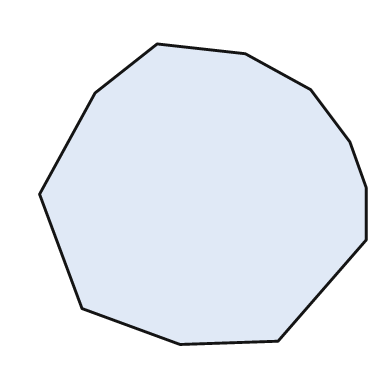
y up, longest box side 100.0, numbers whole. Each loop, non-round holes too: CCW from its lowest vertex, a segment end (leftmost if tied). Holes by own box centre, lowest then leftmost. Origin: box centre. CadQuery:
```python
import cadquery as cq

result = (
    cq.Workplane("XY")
    .moveTo(-7.0, -46.0)
    .lineTo(23.0, -45.0)
    .lineTo(50.0, -14.0)
    .lineTo(50.0, 2.0)
    .lineTo(45.0, 16.0)
    .lineTo(33.0, 32.0)
    .lineTo(13.0, 43.0)
    .lineTo(-14.0, 46.0)
    .lineTo(-33.0, 31.0)
    .lineTo(-50.0, 0.0)
    .lineTo(-37.0, -35.0)
    .close()
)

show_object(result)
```